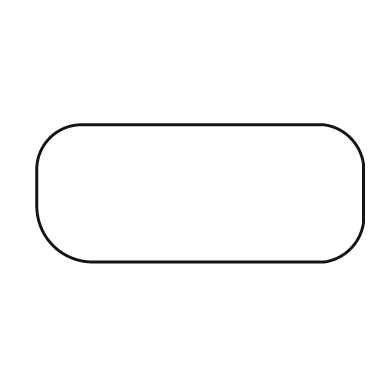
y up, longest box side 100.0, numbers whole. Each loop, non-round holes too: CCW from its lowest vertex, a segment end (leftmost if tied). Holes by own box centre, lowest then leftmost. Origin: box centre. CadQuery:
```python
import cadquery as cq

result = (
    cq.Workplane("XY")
    .moveTo(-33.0, -21.0)
    .lineTo(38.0, -21.0)
    .threePointArc((46.0, -17.0), (50.0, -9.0))
    .lineTo(50.0, 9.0)
    .threePointArc((46.0, 17.0), (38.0, 21.0))
    .lineTo(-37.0, 21.0)
    .threePointArc((-46.0, 17.0), (-50.0, 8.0))
    .lineTo(-50.0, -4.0)
    .threePointArc((-45.0, -16.0), (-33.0, -21.0))
    .close()
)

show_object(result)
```